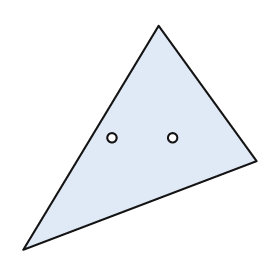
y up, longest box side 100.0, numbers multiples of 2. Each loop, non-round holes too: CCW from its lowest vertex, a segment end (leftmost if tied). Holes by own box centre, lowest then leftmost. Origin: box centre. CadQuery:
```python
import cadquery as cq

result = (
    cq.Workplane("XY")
    .moveTo(-50.0, -48.0)
    .lineTo(50.0, -10.0)
    .lineTo(8.0, 48.0)
    .close()
    .moveTo(-12.0, 0.0)
    .circle(2.0)
    .moveTo(14.0, 0.0)
    .circle(2.0)
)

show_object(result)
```